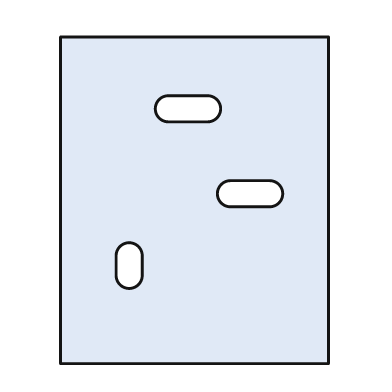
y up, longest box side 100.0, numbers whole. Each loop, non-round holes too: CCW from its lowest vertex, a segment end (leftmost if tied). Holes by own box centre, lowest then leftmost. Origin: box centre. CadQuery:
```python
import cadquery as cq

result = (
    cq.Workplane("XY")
    .moveTo(-41.0, -50.0)
    .lineTo(41.0, -50.0)
    .lineTo(41.0, 50.0)
    .lineTo(-41.0, 50.0)
    .close()
    .moveTo(-24.0, -23.0)
    .threePointArc((-20.0, -27.0), (-16.0, -23.0))
    .lineTo(-16.0, -17.0)
    .threePointArc((-20.0, -13.0), (-24.0, -17.0))
    .close()
    .moveTo(11.0, -2.0)
    .lineTo(23.0, -2.0)
    .threePointArc((27.0, 2.0), (23.0, 6.0))
    .lineTo(11.0, 6.0)
    .threePointArc((7.0, 2.0), (11.0, -2.0))
    .close()
    .moveTo(-8.0, 24.0)
    .lineTo(4.0, 24.0)
    .threePointArc((8.0, 28.0), (4.0, 32.0))
    .lineTo(-8.0, 32.0)
    .threePointArc((-12.0, 28.0), (-8.0, 24.0))
    .close()
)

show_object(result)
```